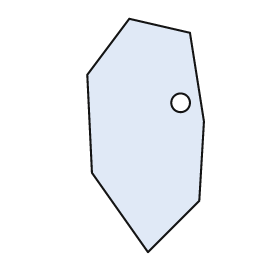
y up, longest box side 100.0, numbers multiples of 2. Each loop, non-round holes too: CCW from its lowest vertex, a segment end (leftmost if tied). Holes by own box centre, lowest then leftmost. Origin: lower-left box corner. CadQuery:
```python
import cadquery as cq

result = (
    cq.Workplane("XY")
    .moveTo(26.0, 0.0)
    .lineTo(48.0, 22.0)
    .lineTo(50.0, 56.0)
    .lineTo(44.0, 94.0)
    .lineTo(18.0, 100.0)
    .lineTo(0.0, 76.0)
    .lineTo(2.0, 34.0)
    .close()
    .moveTo(40.0, 64.0)
    .circle(4.0)
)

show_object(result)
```